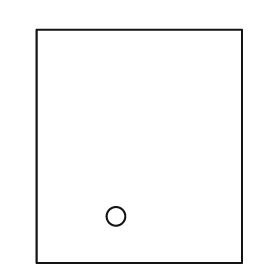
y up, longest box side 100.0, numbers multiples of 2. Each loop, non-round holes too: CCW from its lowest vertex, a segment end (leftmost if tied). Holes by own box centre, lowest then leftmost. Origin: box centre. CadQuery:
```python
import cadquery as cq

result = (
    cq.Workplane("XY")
    .moveTo(-44.0, -50.0)
    .lineTo(44.0, -50.0)
    .lineTo(44.0, 50.0)
    .lineTo(-44.0, 50.0)
    .close()
    .moveTo(-10.0, -30.0)
    .circle(4.0)
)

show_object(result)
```